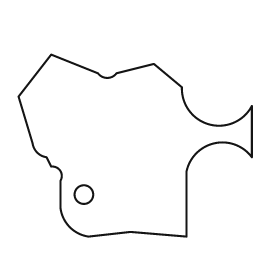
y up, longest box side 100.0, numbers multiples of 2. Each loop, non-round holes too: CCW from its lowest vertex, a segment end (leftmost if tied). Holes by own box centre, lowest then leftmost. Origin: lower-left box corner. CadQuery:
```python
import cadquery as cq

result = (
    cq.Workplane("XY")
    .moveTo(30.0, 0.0)
    .lineTo(48.0, 2.0)
    .lineTo(72.0, 0.0)
    .lineTo(72.0, 28.0)
    .threePointArc((84.0, 40.0), (100.0, 34.0))
    .lineTo(100.0, 56.0)
    .threePointArc((82.0, 48.0), (70.0, 64.0))
    .lineTo(58.0, 74.0)
    .lineTo(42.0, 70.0)
    .threePointArc((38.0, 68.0), (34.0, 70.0))
    .lineTo(14.0, 78.0)
    .lineTo(0.0, 60.0)
    .lineTo(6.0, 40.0)
    .threePointArc((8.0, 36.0), (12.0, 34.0))
    .lineTo(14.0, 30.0)
    .threePointArc((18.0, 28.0), (18.0, 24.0))
    .lineTo(18.0, 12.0)
    .threePointArc((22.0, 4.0), (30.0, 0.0))
    .close()
    .moveTo(28.0, 18.0)
    .circle(4.0)
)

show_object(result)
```